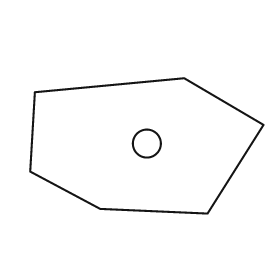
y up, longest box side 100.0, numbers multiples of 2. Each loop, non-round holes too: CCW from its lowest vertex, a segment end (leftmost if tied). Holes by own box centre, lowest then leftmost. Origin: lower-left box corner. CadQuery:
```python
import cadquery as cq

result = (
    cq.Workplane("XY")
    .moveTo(76.0, 0.0)
    .lineTo(100.0, 38.0)
    .lineTo(66.0, 58.0)
    .lineTo(2.0, 52.0)
    .lineTo(0.0, 18.0)
    .lineTo(30.0, 2.0)
    .close()
    .moveTo(50.0, 30.0)
    .circle(6.0)
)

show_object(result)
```